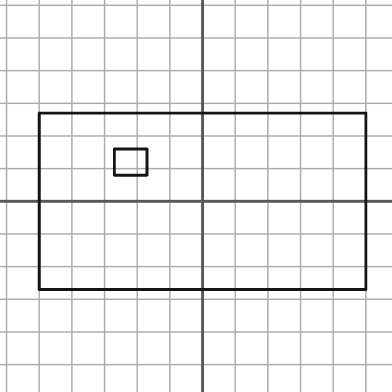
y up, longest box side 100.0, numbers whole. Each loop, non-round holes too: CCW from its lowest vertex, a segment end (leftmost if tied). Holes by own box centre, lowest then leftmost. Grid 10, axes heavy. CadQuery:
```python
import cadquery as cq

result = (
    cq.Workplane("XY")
    .moveTo(-50.0, -27.0)
    .lineTo(50.0, -27.0)
    .lineTo(50.0, 27.0)
    .lineTo(-50.0, 27.0)
    .close()
    .moveTo(-27.0, 8.0)
    .lineTo(-17.0, 8.0)
    .lineTo(-17.0, 16.0)
    .lineTo(-27.0, 16.0)
    .close()
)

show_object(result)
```